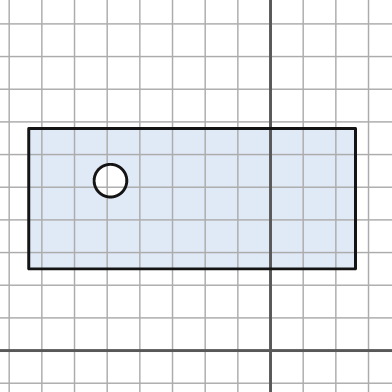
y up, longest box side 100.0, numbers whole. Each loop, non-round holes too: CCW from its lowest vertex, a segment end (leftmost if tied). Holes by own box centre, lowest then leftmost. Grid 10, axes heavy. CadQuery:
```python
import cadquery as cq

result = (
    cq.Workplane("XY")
    .moveTo(-74.0, 25.0)
    .lineTo(26.0, 25.0)
    .lineTo(26.0, 68.0)
    .lineTo(-74.0, 68.0)
    .close()
    .moveTo(-49.0, 52.0)
    .circle(5.0)
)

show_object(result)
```